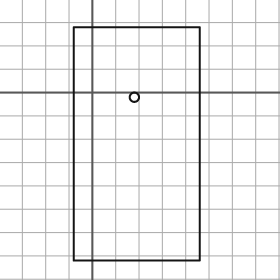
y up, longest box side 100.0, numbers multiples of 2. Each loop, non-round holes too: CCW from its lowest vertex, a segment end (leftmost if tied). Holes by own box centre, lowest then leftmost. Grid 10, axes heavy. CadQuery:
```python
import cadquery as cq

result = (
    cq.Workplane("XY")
    .moveTo(-8.0, -72.0)
    .lineTo(46.0, -72.0)
    .lineTo(46.0, 28.0)
    .lineTo(-8.0, 28.0)
    .close()
    .moveTo(18.0, -2.0)
    .circle(2.0)
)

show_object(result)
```